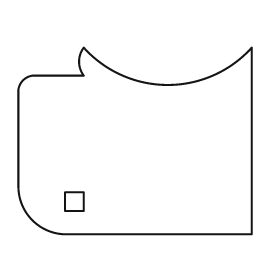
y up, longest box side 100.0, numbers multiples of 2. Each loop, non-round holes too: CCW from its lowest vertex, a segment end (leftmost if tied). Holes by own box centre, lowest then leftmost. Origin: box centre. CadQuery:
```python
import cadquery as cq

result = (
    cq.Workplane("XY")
    .moveTo(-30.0, -40.0)
    .lineTo(50.0, -40.0)
    .lineTo(50.0, 40.0)
    .threePointArc((14.0, 24.0), (-22.0, 40.0))
    .threePointArc((-24.0, 34.0), (-22.0, 28.0))
    .lineTo(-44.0, 28.0)
    .threePointArc((-48.0, 26.0), (-50.0, 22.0))
    .lineTo(-50.0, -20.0)
    .threePointArc((-44.0, -34.0), (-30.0, -40.0))
    .close()
    .moveTo(-30.0, -30.0)
    .lineTo(-22.0, -30.0)
    .lineTo(-22.0, -22.0)
    .lineTo(-30.0, -22.0)
    .close()
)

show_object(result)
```